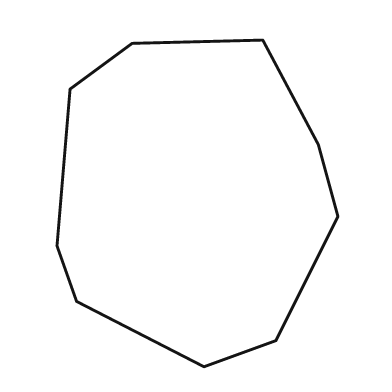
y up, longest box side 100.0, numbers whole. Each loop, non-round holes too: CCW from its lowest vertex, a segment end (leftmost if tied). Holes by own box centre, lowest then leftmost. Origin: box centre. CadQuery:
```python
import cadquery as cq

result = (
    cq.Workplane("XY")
    .moveTo(2.0, -50.0)
    .lineTo(24.0, -42.0)
    .lineTo(43.0, -4.0)
    .lineTo(37.0, 18.0)
    .lineTo(20.0, 50.0)
    .lineTo(-20.0, 49.0)
    .lineTo(-39.0, 35.0)
    .lineTo(-43.0, -13.0)
    .lineTo(-37.0, -30.0)
    .close()
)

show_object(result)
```